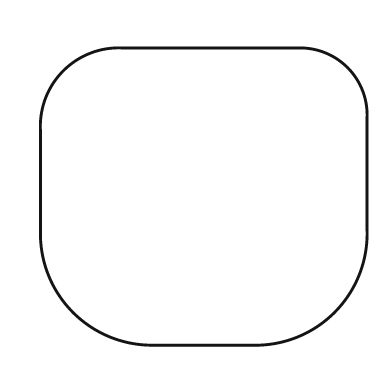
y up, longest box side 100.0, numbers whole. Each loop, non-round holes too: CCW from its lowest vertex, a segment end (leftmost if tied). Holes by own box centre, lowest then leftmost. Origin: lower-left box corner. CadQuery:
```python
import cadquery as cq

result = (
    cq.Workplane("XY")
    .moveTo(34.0, 0.0)
    .lineTo(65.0, 0.0)
    .threePointArc((90.0, 10.0), (100.0, 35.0))
    .lineTo(100.0, 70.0)
    .threePointArc((94.0, 85.0), (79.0, 91.0))
    .lineTo(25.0, 91.0)
    .threePointArc((7.0, 84.0), (0.0, 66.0))
    .lineTo(0.0, 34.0)
    .threePointArc((10.0, 10.0), (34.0, 0.0))
    .close()
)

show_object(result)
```